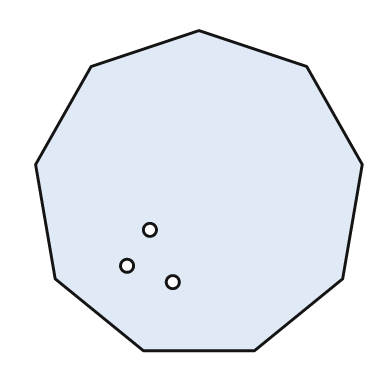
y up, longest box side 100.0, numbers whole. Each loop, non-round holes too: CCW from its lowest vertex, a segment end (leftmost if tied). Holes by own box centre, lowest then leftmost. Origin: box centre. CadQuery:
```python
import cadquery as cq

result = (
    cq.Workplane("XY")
    .moveTo(-17.0, -49.0)
    .lineTo(17.0, -49.0)
    .lineTo(44.0, -27.0)
    .lineTo(50.0, 8.0)
    .lineTo(33.0, 38.0)
    .lineTo(0.0, 49.0)
    .lineTo(-33.0, 38.0)
    .lineTo(-50.0, 8.0)
    .lineTo(-44.0, -27.0)
    .close()
    .moveTo(-8.0, -28.0)
    .circle(2.0)
    .moveTo(-22.0, -23.0)
    .circle(2.0)
    .moveTo(-15.0, -12.0)
    .circle(2.0)
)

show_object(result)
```